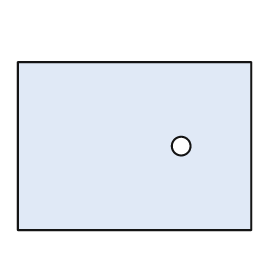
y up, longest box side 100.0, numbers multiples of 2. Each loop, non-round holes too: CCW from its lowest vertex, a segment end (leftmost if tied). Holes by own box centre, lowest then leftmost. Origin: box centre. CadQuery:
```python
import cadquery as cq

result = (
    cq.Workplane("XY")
    .moveTo(-50.0, -36.0)
    .lineTo(50.0, -36.0)
    .lineTo(50.0, 36.0)
    .lineTo(-50.0, 36.0)
    .close()
    .moveTo(20.0, 0.0)
    .circle(4.0)
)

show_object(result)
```